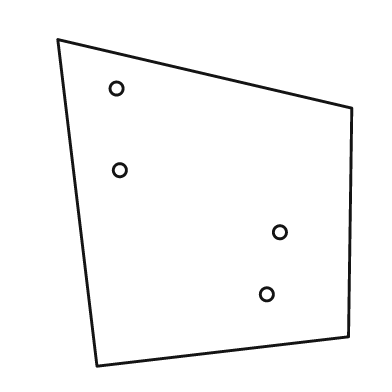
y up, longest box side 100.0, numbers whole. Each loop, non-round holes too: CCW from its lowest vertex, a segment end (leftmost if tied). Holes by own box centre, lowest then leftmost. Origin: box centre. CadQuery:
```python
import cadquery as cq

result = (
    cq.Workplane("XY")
    .moveTo(-33.0, -50.0)
    .lineTo(44.0, -41.0)
    .lineTo(45.0, 29.0)
    .lineTo(-45.0, 50.0)
    .close()
    .moveTo(19.0, -28.0)
    .circle(2.0)
    .moveTo(23.0, -9.0)
    .circle(2.0)
    .moveTo(-26.0, 10.0)
    .circle(2.0)
    .moveTo(-27.0, 35.0)
    .circle(2.0)
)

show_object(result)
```